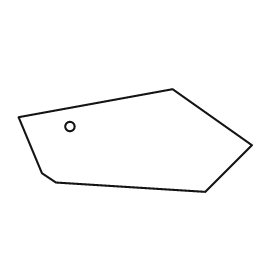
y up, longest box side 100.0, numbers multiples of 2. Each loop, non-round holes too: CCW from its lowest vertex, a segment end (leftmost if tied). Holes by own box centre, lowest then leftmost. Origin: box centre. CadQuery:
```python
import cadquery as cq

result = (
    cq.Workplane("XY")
    .moveTo(30.0, -22.0)
    .lineTo(50.0, -2.0)
    .lineTo(16.0, 22.0)
    .lineTo(-50.0, 10.0)
    .lineTo(-40.0, -14.0)
    .lineTo(-34.0, -18.0)
    .close()
    .moveTo(-28.0, 6.0)
    .circle(2.0)
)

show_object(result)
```